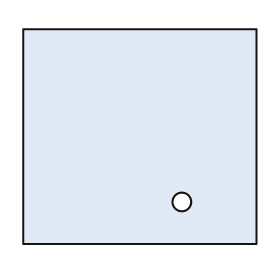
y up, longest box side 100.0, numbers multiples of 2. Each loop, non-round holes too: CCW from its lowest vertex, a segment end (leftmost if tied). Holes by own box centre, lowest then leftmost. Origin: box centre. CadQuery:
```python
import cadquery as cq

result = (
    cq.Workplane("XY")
    .moveTo(-50.0, -46.0)
    .lineTo(50.0, -46.0)
    .lineTo(50.0, 46.0)
    .lineTo(-50.0, 46.0)
    .close()
    .moveTo(18.0, -28.0)
    .circle(4.0)
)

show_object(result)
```